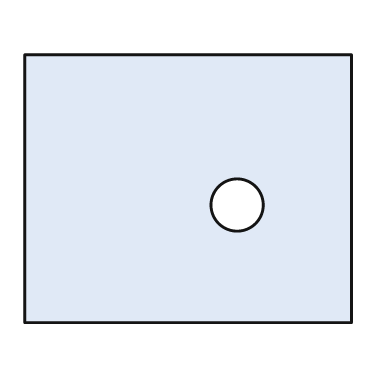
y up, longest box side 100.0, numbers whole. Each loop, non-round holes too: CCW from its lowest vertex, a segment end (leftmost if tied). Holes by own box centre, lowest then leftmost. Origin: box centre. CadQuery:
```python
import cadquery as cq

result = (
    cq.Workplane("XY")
    .moveTo(-50.0, -41.0)
    .lineTo(50.0, -41.0)
    .lineTo(50.0, 41.0)
    .lineTo(-50.0, 41.0)
    .close()
    .moveTo(15.0, -5.0)
    .circle(8.0)
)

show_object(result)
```